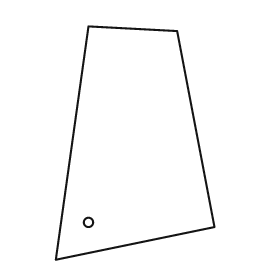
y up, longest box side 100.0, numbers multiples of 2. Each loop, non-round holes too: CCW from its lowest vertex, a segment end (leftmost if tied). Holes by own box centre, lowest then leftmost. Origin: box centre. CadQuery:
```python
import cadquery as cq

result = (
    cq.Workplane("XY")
    .moveTo(-34.0, -50.0)
    .lineTo(34.0, -36.0)
    .lineTo(18.0, 48.0)
    .lineTo(-20.0, 50.0)
    .close()
    .moveTo(-20.0, -34.0)
    .circle(2.0)
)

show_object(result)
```